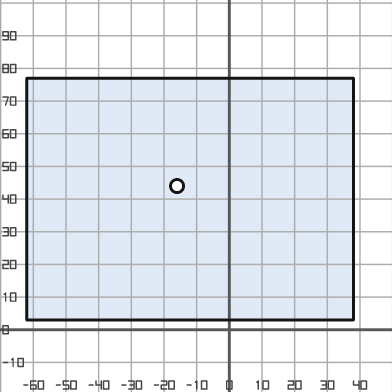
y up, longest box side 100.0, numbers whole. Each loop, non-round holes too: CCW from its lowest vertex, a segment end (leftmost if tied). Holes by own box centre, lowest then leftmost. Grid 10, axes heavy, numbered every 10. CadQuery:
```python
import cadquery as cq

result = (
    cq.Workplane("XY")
    .moveTo(-62.0, 3.0)
    .lineTo(38.0, 3.0)
    .lineTo(38.0, 77.0)
    .lineTo(-62.0, 77.0)
    .close()
    .moveTo(-16.0, 44.0)
    .circle(2.0)
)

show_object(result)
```